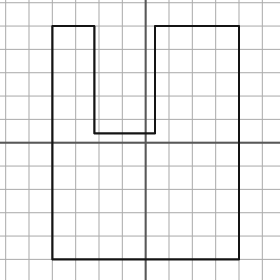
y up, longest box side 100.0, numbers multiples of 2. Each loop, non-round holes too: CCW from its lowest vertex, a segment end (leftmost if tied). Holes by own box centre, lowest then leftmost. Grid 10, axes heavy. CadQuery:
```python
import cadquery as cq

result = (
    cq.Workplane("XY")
    .moveTo(-40.0, -50.0)
    .lineTo(40.0, -50.0)
    .lineTo(40.0, 50.0)
    .lineTo(4.0, 50.0)
    .lineTo(4.0, 4.0)
    .lineTo(-22.0, 4.0)
    .lineTo(-22.0, 50.0)
    .lineTo(-40.0, 50.0)
    .close()
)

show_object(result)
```